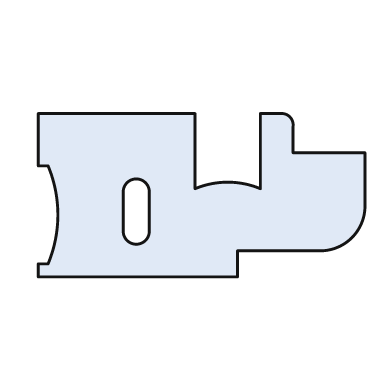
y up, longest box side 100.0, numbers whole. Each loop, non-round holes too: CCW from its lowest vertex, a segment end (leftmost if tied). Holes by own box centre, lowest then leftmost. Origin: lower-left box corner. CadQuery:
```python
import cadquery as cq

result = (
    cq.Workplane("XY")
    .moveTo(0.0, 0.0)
    .lineTo(61.0, 0.0)
    .lineTo(61.0, 8.0)
    .lineTo(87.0, 8.0)
    .threePointArc((96.0, 12.0), (100.0, 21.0))
    .lineTo(100.0, 38.0)
    .lineTo(78.0, 38.0)
    .lineTo(78.0, 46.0)
    .threePointArc((77.0, 49.0), (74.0, 50.0))
    .lineTo(68.0, 50.0)
    .lineTo(68.0, 27.0)
    .threePointArc((58.0, 29.0), (48.0, 27.0))
    .lineTo(48.0, 50.0)
    .lineTo(0.0, 50.0)
    .lineTo(0.0, 34.0)
    .lineTo(3.0, 34.0)
    .threePointArc((6.0, 19.0), (3.0, 4.0))
    .lineTo(0.0, 4.0)
    .close()
    .moveTo(26.0, 14.0)
    .threePointArc((30.0, 10.0), (34.0, 14.0))
    .lineTo(34.0, 26.0)
    .threePointArc((30.0, 30.0), (26.0, 26.0))
    .close()
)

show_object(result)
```